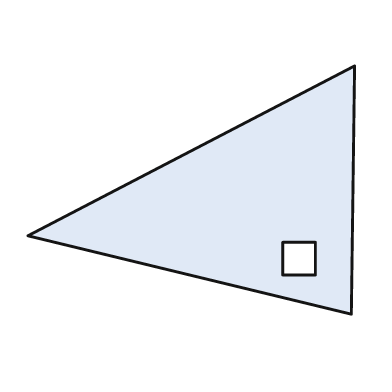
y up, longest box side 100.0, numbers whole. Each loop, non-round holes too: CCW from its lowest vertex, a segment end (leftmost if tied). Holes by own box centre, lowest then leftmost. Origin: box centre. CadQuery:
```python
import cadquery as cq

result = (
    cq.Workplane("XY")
    .moveTo(49.0, -38.0)
    .lineTo(50.0, 38.0)
    .lineTo(-50.0, -14.0)
    .close()
    .moveTo(28.0, -26.0)
    .lineTo(38.0, -26.0)
    .lineTo(38.0, -16.0)
    .lineTo(28.0, -16.0)
    .close()
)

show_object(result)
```